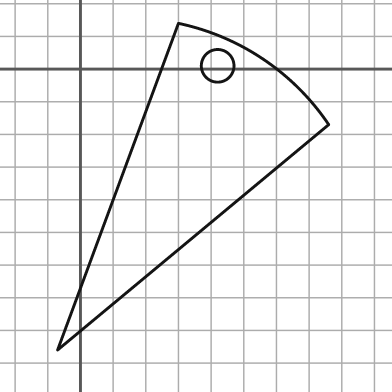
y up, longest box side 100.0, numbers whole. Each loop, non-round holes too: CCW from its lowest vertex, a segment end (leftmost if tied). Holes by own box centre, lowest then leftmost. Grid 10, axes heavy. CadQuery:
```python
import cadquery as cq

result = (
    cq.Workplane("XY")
    .moveTo(-7.0, -86.0)
    .lineTo(76.0, -17.0)
    .threePointArc((56.0, 3.0), (30.0, 14.0))
    .close()
    .moveTo(42.0, 1.0)
    .circle(5.0)
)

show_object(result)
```